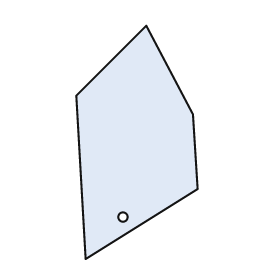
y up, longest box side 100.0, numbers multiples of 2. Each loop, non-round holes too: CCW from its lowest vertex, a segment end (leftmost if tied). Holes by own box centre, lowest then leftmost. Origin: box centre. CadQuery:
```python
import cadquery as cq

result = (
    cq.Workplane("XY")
    .moveTo(-22.0, -50.0)
    .lineTo(26.0, -20.0)
    .lineTo(24.0, 12.0)
    .lineTo(4.0, 50.0)
    .lineTo(-26.0, 20.0)
    .close()
    .moveTo(-6.0, -32.0)
    .circle(2.0)
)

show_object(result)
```